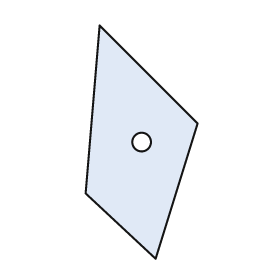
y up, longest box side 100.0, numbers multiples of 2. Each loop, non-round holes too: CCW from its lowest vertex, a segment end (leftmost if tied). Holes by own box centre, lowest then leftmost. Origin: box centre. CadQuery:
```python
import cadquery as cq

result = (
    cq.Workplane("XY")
    .moveTo(6.0, -50.0)
    .lineTo(24.0, 8.0)
    .lineTo(-18.0, 50.0)
    .lineTo(-24.0, -22.0)
    .close()
    .moveTo(0.0, 0.0)
    .circle(4.0)
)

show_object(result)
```